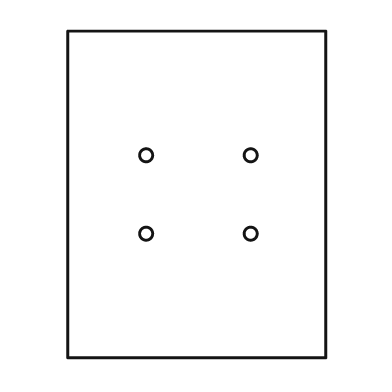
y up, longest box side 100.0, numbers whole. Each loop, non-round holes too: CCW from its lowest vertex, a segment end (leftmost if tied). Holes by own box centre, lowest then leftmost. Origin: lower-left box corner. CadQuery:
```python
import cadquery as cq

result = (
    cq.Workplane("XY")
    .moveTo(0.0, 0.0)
    .lineTo(79.0, 0.0)
    .lineTo(79.0, 100.0)
    .lineTo(0.0, 100.0)
    .close()
    .moveTo(24.0, 38.0)
    .circle(2.0)
    .moveTo(56.0, 38.0)
    .circle(2.0)
    .moveTo(24.0, 62.0)
    .circle(2.0)
    .moveTo(56.0, 62.0)
    .circle(2.0)
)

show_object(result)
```